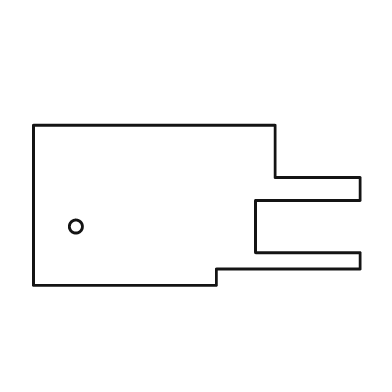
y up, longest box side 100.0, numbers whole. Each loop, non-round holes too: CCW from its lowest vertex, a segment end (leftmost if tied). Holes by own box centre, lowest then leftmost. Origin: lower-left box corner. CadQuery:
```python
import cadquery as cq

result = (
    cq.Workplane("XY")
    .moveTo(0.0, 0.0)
    .lineTo(56.0, 0.0)
    .lineTo(56.0, 5.0)
    .lineTo(100.0, 5.0)
    .lineTo(100.0, 10.0)
    .lineTo(68.0, 10.0)
    .lineTo(68.0, 26.0)
    .lineTo(100.0, 26.0)
    .lineTo(100.0, 33.0)
    .lineTo(74.0, 33.0)
    .lineTo(74.0, 49.0)
    .lineTo(0.0, 49.0)
    .close()
    .moveTo(13.0, 18.0)
    .circle(2.0)
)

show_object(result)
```